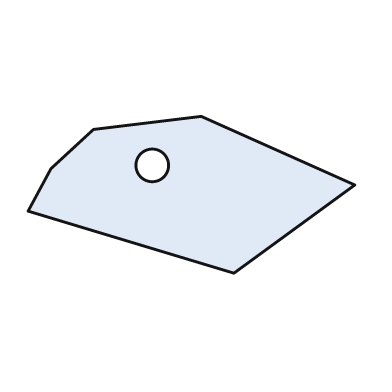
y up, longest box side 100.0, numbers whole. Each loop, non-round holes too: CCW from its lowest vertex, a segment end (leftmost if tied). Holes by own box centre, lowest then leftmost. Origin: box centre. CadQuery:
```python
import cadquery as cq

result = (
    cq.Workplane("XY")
    .moveTo(13.0, -24.0)
    .lineTo(50.0, 3.0)
    .lineTo(3.0, 24.0)
    .lineTo(-30.0, 20.0)
    .lineTo(-43.0, 8.0)
    .lineTo(-50.0, -5.0)
    .close()
    .moveTo(-12.0, 9.0)
    .circle(5.0)
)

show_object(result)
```